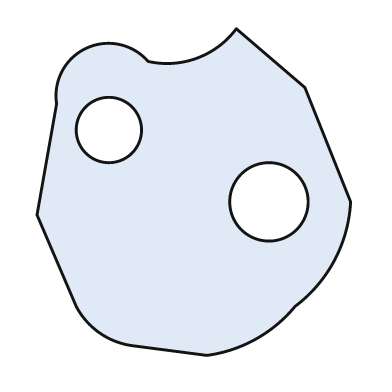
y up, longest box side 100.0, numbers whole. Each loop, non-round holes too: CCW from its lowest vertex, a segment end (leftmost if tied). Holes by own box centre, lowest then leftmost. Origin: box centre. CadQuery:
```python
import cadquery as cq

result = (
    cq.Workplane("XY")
    .moveTo(4.0, -50.0)
    .threePointArc((19.0, -45.0), (31.0, -35.0))
    .threePointArc((43.0, -21.0), (48.0, -3.0))
    .lineTo(34.0, 32.0)
    .lineTo(13.0, 50.0)
    .threePointArc((1.0, 41.0), (-14.0, 40.0))
    .threePointArc((-33.0, 44.0), (-42.0, 27.0))
    .lineTo(-48.0, -7.0)
    .lineTo(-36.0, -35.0)
    .threePointArc((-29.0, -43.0), (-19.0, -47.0))
    .close()
    .moveTo(23.0, -3.0)
    .circle(12.0)
    .moveTo(-26.0, 19.0)
    .circle(10.0)
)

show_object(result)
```